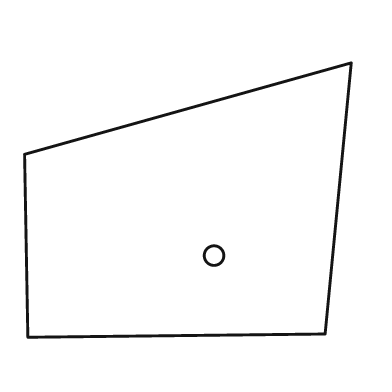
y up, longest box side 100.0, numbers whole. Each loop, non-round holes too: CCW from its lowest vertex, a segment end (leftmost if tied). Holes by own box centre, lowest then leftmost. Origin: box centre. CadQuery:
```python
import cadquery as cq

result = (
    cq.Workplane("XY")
    .moveTo(-49.0, -42.0)
    .lineTo(42.0, -41.0)
    .lineTo(50.0, 42.0)
    .lineTo(-50.0, 14.0)
    .close()
    .moveTo(8.0, -17.0)
    .circle(3.0)
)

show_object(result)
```